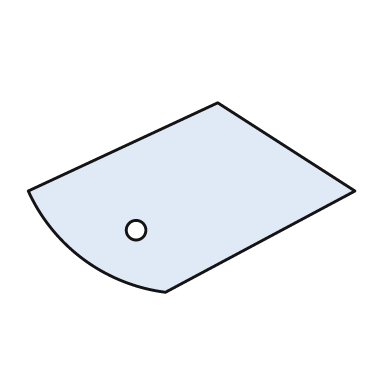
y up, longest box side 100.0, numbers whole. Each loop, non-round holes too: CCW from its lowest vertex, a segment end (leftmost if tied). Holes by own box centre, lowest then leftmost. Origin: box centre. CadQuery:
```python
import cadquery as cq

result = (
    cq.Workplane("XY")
    .moveTo(-8.0, -29.0)
    .lineTo(50.0, 2.0)
    .lineTo(8.0, 29.0)
    .lineTo(-50.0, 2.0)
    .threePointArc((-33.0, -19.0), (-8.0, -29.0))
    .close()
    .moveTo(-17.0, -10.0)
    .circle(3.0)
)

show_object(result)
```